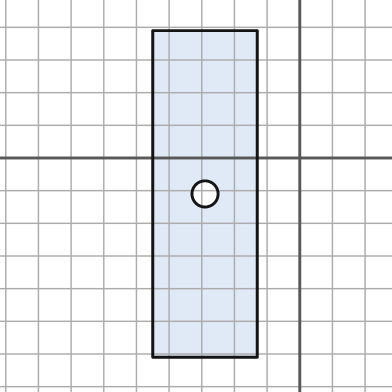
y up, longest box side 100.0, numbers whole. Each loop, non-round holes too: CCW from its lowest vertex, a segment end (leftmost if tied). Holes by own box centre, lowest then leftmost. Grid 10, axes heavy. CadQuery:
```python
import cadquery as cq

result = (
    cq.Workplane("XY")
    .moveTo(-45.0, -61.0)
    .lineTo(-13.0, -61.0)
    .lineTo(-13.0, 39.0)
    .lineTo(-45.0, 39.0)
    .close()
    .moveTo(-29.0, -11.0)
    .circle(4.0)
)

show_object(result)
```